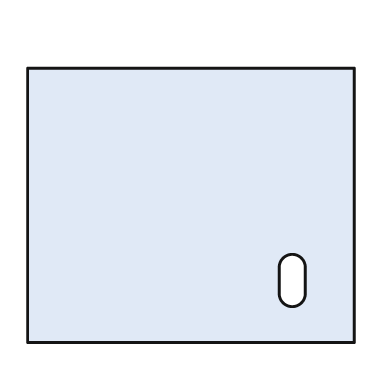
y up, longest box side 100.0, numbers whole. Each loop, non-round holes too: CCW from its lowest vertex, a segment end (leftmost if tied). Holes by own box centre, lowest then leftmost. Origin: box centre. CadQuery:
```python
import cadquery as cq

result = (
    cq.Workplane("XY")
    .moveTo(-50.0, -42.0)
    .lineTo(50.0, -42.0)
    .lineTo(50.0, 42.0)
    .lineTo(-50.0, 42.0)
    .close()
    .moveTo(27.0, -27.0)
    .threePointArc((31.0, -31.0), (35.0, -27.0))
    .lineTo(35.0, -19.0)
    .threePointArc((31.0, -15.0), (27.0, -19.0))
    .close()
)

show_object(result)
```